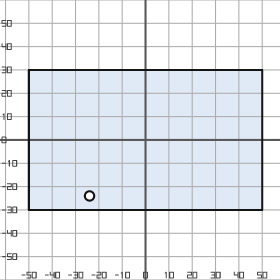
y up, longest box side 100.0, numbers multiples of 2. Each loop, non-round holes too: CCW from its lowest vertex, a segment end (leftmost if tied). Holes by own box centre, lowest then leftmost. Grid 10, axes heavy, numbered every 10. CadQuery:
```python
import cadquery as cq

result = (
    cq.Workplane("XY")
    .moveTo(-50.0, -30.0)
    .lineTo(50.0, -30.0)
    .lineTo(50.0, 30.0)
    .lineTo(-50.0, 30.0)
    .close()
    .moveTo(-24.0, -24.0)
    .circle(2.0)
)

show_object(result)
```